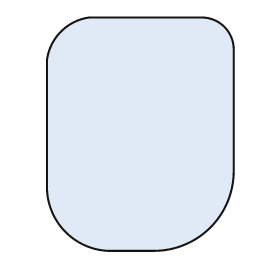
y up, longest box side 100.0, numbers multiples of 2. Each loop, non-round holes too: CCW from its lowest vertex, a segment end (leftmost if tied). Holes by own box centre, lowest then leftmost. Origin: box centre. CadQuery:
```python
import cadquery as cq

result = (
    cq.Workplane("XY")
    .moveTo(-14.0, -50.0)
    .lineTo(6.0, -50.0)
    .threePointArc((30.0, -40.0), (40.0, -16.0))
    .lineTo(40.0, 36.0)
    .threePointArc((36.0, 46.0), (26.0, 50.0))
    .lineTo(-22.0, 50.0)
    .threePointArc((-34.0, 44.0), (-40.0, 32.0))
    .lineTo(-40.0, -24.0)
    .threePointArc((-32.0, -42.0), (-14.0, -50.0))
    .close()
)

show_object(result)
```